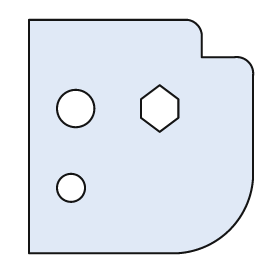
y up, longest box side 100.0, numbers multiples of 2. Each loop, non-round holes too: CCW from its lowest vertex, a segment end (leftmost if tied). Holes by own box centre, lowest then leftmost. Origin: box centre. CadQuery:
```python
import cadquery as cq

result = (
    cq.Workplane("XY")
    .moveTo(-48.0, -50.0)
    .lineTo(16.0, -50.0)
    .threePointArc((38.0, -40.0), (48.0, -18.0))
    .lineTo(48.0, 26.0)
    .threePointArc((46.0, 32.0), (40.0, 34.0))
    .lineTo(26.0, 34.0)
    .lineTo(26.0, 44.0)
    .threePointArc((24.0, 48.0), (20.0, 50.0))
    .lineTo(-48.0, 50.0)
    .close()
    .moveTo(-30.0, -22.0)
    .circle(6.0)
    .moveTo(-28.0, 12.0)
    .circle(8.0)
    .moveTo(8.0, 2.0)
    .lineTo(16.0, 8.0)
    .lineTo(16.0, 16.0)
    .lineTo(8.0, 22.0)
    .lineTo(0.0, 16.0)
    .lineTo(0.0, 8.0)
    .close()
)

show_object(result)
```